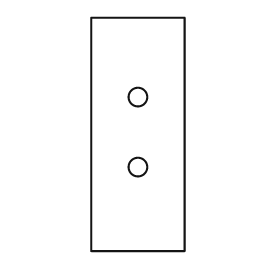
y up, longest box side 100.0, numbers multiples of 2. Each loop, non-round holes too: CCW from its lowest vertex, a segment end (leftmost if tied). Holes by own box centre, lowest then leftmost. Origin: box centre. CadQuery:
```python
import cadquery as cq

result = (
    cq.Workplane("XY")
    .moveTo(-20.0, -50.0)
    .lineTo(20.0, -50.0)
    .lineTo(20.0, 50.0)
    .lineTo(-20.0, 50.0)
    .close()
    .moveTo(0.0, -14.0)
    .circle(4.0)
    .moveTo(0.0, 16.0)
    .circle(4.0)
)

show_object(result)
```